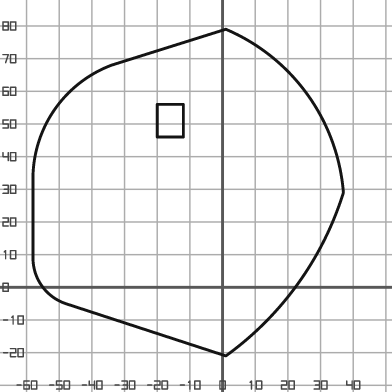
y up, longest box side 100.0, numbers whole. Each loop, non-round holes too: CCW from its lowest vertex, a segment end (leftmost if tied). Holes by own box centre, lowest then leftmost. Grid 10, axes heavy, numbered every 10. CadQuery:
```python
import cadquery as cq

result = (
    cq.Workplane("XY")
    .moveTo(1.0, -21.0)
    .threePointArc((23.0, 1.0), (37.0, 29.0))
    .threePointArc((26.0, 59.0), (1.0, 79.0))
    .lineTo(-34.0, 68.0)
    .threePointArc((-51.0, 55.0), (-58.0, 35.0))
    .lineTo(-58.0, 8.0)
    .threePointArc((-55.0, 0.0), (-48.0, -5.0))
    .close()
    .moveTo(-20.0, 46.0)
    .lineTo(-12.0, 46.0)
    .lineTo(-12.0, 56.0)
    .lineTo(-20.0, 56.0)
    .close()
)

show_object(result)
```